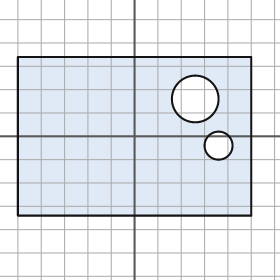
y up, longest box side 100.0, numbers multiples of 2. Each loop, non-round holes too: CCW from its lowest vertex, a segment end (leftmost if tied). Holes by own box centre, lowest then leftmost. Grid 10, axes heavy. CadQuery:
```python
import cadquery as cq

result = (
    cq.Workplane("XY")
    .moveTo(-50.0, -34.0)
    .lineTo(50.0, -34.0)
    .lineTo(50.0, 34.0)
    .lineTo(-50.0, 34.0)
    .close()
    .moveTo(36.0, -4.0)
    .circle(6.0)
    .moveTo(26.0, 16.0)
    .circle(10.0)
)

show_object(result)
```